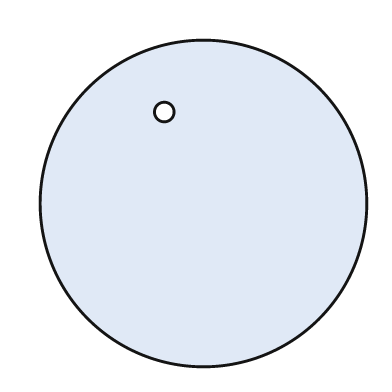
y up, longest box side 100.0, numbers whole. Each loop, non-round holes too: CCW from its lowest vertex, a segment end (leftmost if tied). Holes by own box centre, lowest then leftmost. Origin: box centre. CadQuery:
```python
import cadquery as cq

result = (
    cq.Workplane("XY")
    .moveTo(0.0, 0.0)
    .circle(50.0)
    .moveTo(-12.0, 28.0)
    .circle(3.0)
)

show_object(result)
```